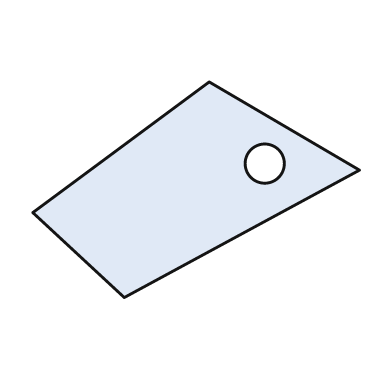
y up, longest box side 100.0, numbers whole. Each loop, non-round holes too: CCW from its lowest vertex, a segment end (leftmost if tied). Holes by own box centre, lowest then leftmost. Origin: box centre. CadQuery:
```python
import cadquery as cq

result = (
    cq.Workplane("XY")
    .moveTo(-22.0, -33.0)
    .lineTo(50.0, 6.0)
    .lineTo(4.0, 33.0)
    .lineTo(-50.0, -7.0)
    .close()
    .moveTo(21.0, 8.0)
    .circle(6.0)
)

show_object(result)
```